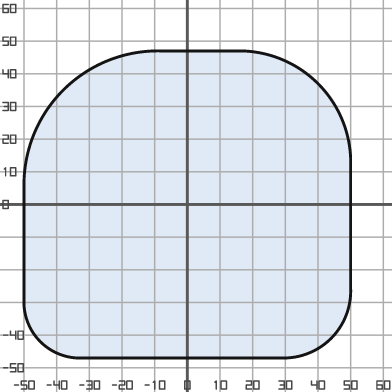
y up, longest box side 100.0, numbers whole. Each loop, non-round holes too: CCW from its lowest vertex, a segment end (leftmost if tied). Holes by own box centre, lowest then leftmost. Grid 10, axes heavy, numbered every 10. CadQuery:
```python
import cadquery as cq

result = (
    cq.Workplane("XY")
    .moveTo(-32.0, -47.0)
    .lineTo(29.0, -47.0)
    .threePointArc((44.0, -41.0), (50.0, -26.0))
    .lineTo(50.0, 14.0)
    .threePointArc((40.0, 37.0), (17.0, 47.0))
    .lineTo(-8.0, 47.0)
    .threePointArc((-38.0, 35.0), (-50.0, 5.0))
    .lineTo(-50.0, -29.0)
    .threePointArc((-45.0, -42.0), (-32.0, -47.0))
    .close()
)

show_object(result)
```